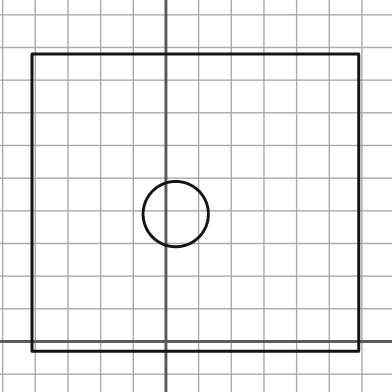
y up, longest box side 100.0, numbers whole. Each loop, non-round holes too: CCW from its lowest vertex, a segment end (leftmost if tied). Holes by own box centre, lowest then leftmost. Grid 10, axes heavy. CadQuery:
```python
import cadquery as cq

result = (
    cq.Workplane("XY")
    .moveTo(-41.0, -3.0)
    .lineTo(59.0, -3.0)
    .lineTo(59.0, 88.0)
    .lineTo(-41.0, 88.0)
    .close()
    .moveTo(3.0, 39.0)
    .circle(10.0)
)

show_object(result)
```